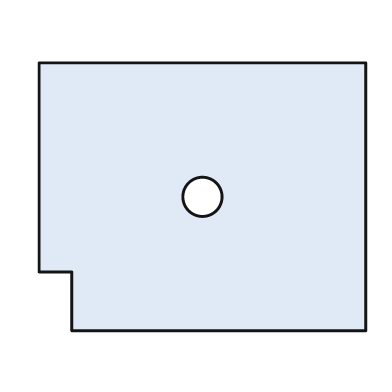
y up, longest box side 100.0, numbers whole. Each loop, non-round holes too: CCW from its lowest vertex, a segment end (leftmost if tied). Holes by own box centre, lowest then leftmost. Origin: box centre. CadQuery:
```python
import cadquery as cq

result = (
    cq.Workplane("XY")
    .moveTo(-40.0, -41.0)
    .lineTo(50.0, -41.0)
    .lineTo(50.0, 41.0)
    .lineTo(-50.0, 41.0)
    .lineTo(-50.0, -23.0)
    .lineTo(-40.0, -23.0)
    .close()
    .moveTo(0.0, 0.0)
    .circle(6.0)
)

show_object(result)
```